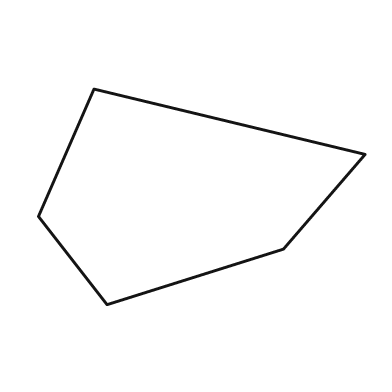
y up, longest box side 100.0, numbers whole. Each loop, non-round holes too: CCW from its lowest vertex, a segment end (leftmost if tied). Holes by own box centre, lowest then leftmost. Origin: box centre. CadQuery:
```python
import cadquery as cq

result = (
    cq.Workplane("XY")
    .moveTo(-29.0, -33.0)
    .lineTo(25.0, -16.0)
    .lineTo(50.0, 13.0)
    .lineTo(-33.0, 33.0)
    .lineTo(-50.0, -6.0)
    .close()
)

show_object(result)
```